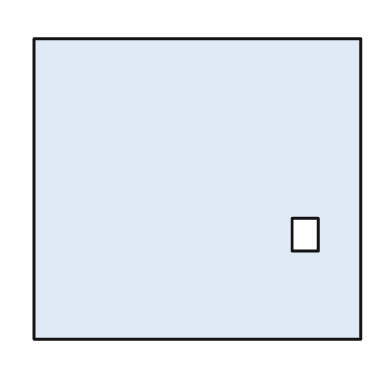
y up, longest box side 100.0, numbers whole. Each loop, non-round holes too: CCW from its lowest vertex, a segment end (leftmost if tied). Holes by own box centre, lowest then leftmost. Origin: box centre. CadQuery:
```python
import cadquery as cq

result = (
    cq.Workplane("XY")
    .moveTo(-50.0, -46.0)
    .lineTo(50.0, -46.0)
    .lineTo(50.0, 46.0)
    .lineTo(-50.0, 46.0)
    .close()
    .moveTo(29.0, -19.0)
    .lineTo(37.0, -19.0)
    .lineTo(37.0, -9.0)
    .lineTo(29.0, -9.0)
    .close()
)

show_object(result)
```